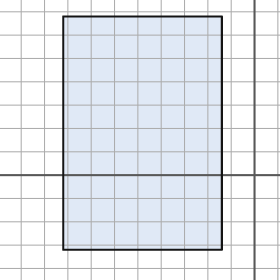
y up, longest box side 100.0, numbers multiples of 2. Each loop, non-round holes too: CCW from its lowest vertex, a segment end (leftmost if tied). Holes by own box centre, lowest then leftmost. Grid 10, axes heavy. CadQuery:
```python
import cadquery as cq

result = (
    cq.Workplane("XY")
    .moveTo(-82.0, -32.0)
    .lineTo(-14.0, -32.0)
    .lineTo(-14.0, 68.0)
    .lineTo(-82.0, 68.0)
    .close()
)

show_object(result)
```